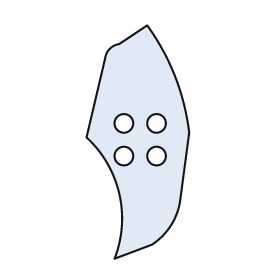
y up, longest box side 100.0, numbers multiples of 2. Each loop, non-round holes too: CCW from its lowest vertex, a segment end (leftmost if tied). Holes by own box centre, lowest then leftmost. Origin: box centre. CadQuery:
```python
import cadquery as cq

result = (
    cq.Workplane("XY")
    .moveTo(-10.0, -50.0)
    .lineTo(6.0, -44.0)
    .threePointArc((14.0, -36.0), (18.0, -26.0))
    .lineTo(22.0, 4.0)
    .threePointArc((16.0, 28.0), (4.0, 50.0))
    .lineTo(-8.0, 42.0)
    .threePointArc((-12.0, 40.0), (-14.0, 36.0))
    .lineTo(-22.0, 2.0)
    .threePointArc((-8.0, -22.0), (-10.0, -50.0))
    .close()
    .moveTo(-6.0, -6.0)
    .circle(4.0)
    .moveTo(8.0, -6.0)
    .circle(4.0)
    .moveTo(-6.0, 8.0)
    .circle(4.0)
    .moveTo(8.0, 8.0)
    .circle(4.0)
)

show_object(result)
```